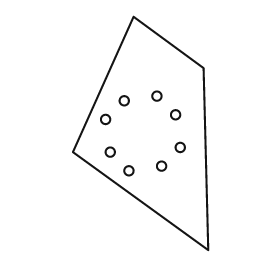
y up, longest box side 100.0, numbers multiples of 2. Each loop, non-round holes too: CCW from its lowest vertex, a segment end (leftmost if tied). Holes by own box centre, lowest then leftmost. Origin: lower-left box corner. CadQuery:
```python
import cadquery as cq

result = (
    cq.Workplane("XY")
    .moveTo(58.0, 0.0)
    .lineTo(56.0, 78.0)
    .lineTo(26.0, 100.0)
    .lineTo(0.0, 42.0)
    .close()
    .moveTo(24.0, 34.0)
    .circle(2.0)
    .moveTo(38.0, 36.0)
    .circle(2.0)
    .moveTo(16.0, 42.0)
    .circle(2.0)
    .moveTo(46.0, 44.0)
    .circle(2.0)
    .moveTo(14.0, 56.0)
    .circle(2.0)
    .moveTo(44.0, 58.0)
    .circle(2.0)
    .moveTo(22.0, 64.0)
    .circle(2.0)
    .moveTo(36.0, 66.0)
    .circle(2.0)
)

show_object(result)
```